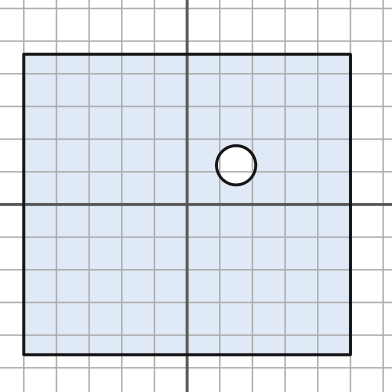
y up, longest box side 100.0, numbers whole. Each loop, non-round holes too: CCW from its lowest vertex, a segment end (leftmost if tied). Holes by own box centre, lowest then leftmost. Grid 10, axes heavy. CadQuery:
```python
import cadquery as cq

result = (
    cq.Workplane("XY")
    .moveTo(-50.0, -46.0)
    .lineTo(50.0, -46.0)
    .lineTo(50.0, 46.0)
    .lineTo(-50.0, 46.0)
    .close()
    .moveTo(15.0, 12.0)
    .circle(6.0)
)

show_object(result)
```